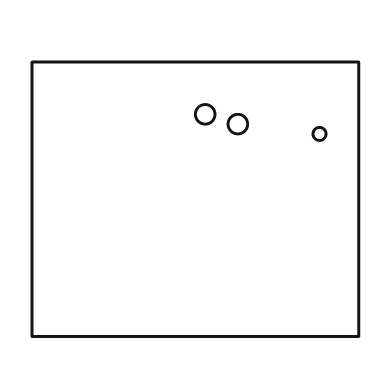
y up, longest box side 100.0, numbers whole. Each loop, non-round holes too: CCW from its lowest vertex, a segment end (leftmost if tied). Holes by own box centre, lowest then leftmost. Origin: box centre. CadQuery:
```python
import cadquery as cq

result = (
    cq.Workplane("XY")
    .moveTo(-50.0, -42.0)
    .lineTo(50.0, -42.0)
    .lineTo(50.0, 42.0)
    .lineTo(-50.0, 42.0)
    .close()
    .moveTo(38.0, 20.0)
    .circle(2.0)
    .moveTo(13.0, 23.0)
    .circle(3.0)
    .moveTo(3.0, 26.0)
    .circle(3.0)
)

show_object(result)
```